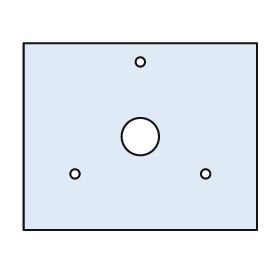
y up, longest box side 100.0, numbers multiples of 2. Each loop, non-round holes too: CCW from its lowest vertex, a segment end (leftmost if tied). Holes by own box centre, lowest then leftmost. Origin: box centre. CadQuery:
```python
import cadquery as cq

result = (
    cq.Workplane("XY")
    .moveTo(-50.0, -40.0)
    .lineTo(50.0, -40.0)
    .lineTo(50.0, 40.0)
    .lineTo(-50.0, 40.0)
    .close()
    .moveTo(-28.0, -16.0)
    .circle(2.0)
    .moveTo(28.0, -16.0)
    .circle(2.0)
    .moveTo(0.0, 0.0)
    .circle(8.0)
    .moveTo(0.0, 32.0)
    .circle(2.0)
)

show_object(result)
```